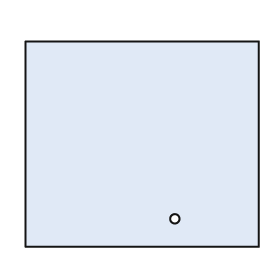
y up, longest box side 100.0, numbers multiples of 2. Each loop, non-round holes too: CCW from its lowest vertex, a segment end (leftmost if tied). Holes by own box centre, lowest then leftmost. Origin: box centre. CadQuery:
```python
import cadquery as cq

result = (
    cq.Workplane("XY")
    .moveTo(-50.0, -44.0)
    .lineTo(50.0, -44.0)
    .lineTo(50.0, 44.0)
    .lineTo(-50.0, 44.0)
    .close()
    .moveTo(14.0, -32.0)
    .circle(2.0)
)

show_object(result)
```